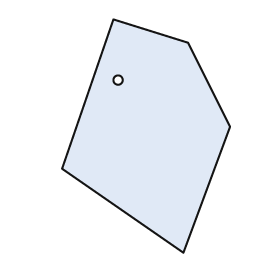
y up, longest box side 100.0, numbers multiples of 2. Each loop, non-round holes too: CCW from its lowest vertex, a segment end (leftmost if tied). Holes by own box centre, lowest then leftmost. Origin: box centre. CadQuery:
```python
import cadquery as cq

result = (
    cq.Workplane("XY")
    .moveTo(16.0, -50.0)
    .lineTo(36.0, 4.0)
    .lineTo(18.0, 40.0)
    .lineTo(-14.0, 50.0)
    .lineTo(-36.0, -14.0)
    .close()
    .moveTo(-12.0, 24.0)
    .circle(2.0)
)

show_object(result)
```